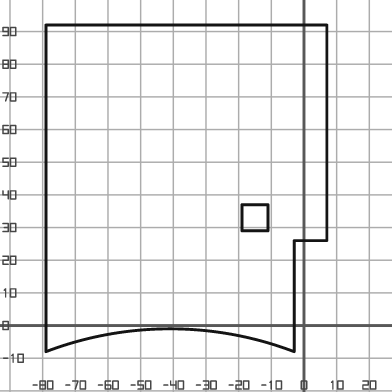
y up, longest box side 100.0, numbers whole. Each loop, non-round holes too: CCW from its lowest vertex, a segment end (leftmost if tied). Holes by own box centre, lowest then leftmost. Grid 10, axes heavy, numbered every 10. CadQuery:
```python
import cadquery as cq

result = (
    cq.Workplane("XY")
    .moveTo(-79.0, -8.0)
    .threePointArc((-41.0, -1.0), (-3.0, -8.0))
    .lineTo(-3.0, 26.0)
    .lineTo(7.0, 26.0)
    .lineTo(7.0, 92.0)
    .lineTo(-79.0, 92.0)
    .close()
    .moveTo(-19.0, 29.0)
    .lineTo(-11.0, 29.0)
    .lineTo(-11.0, 37.0)
    .lineTo(-19.0, 37.0)
    .close()
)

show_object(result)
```